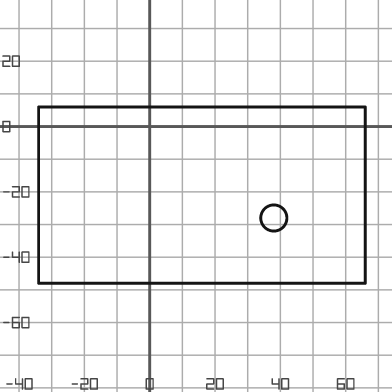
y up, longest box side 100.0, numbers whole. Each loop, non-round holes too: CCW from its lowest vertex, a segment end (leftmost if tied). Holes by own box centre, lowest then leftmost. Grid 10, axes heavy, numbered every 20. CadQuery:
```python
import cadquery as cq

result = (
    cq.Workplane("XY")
    .moveTo(-34.0, -48.0)
    .lineTo(66.0, -48.0)
    .lineTo(66.0, 6.0)
    .lineTo(-34.0, 6.0)
    .close()
    .moveTo(38.0, -28.0)
    .circle(4.0)
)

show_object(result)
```